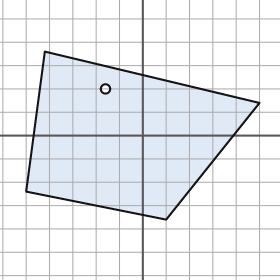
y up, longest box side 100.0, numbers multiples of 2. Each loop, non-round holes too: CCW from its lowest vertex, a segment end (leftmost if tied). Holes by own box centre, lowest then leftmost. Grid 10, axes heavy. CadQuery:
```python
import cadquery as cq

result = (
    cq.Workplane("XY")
    .moveTo(10.0, -36.0)
    .lineTo(50.0, 14.0)
    .lineTo(-42.0, 36.0)
    .lineTo(-50.0, -24.0)
    .close()
    .moveTo(-16.0, 20.0)
    .circle(2.0)
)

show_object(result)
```